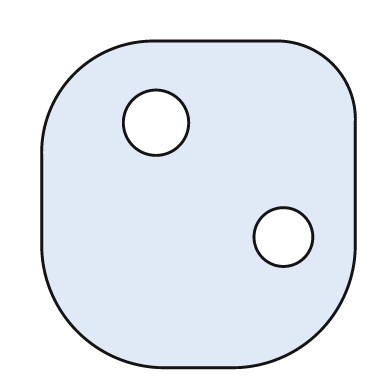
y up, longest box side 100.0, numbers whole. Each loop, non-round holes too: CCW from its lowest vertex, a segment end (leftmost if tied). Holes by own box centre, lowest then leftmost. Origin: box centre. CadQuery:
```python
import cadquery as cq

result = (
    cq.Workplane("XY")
    .moveTo(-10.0, -50.0)
    .lineTo(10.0, -50.0)
    .threePointArc((37.0, -39.0), (48.0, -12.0))
    .lineTo(48.0, 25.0)
    .threePointArc((41.0, 43.0), (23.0, 50.0))
    .lineTo(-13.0, 50.0)
    .threePointArc((-38.0, 40.0), (-48.0, 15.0))
    .lineTo(-48.0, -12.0)
    .threePointArc((-37.0, -39.0), (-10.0, -50.0))
    .close()
    .moveTo(26.0, -10.0)
    .circle(9.0)
    .moveTo(-13.0, 25.0)
    .circle(10.0)
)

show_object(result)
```